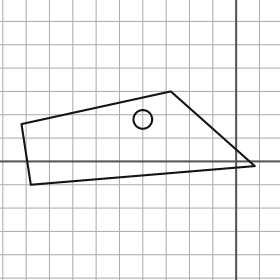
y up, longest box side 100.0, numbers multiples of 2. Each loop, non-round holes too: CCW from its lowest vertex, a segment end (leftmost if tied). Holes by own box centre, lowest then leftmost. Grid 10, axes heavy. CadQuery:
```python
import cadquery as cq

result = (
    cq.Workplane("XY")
    .moveTo(-88.0, -10.0)
    .lineTo(8.0, -2.0)
    .lineTo(-28.0, 30.0)
    .lineTo(-92.0, 16.0)
    .close()
    .moveTo(-40.0, 18.0)
    .circle(4.0)
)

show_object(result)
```